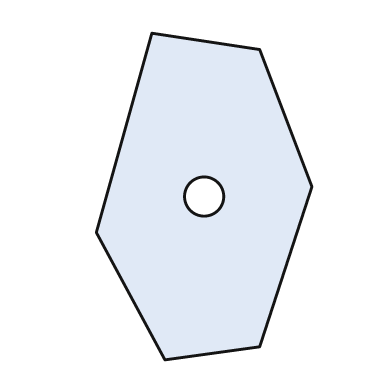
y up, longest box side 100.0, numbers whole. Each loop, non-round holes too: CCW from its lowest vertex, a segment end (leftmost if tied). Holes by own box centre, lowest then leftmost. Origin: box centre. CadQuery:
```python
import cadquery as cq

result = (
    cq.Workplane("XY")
    .moveTo(-12.0, -50.0)
    .lineTo(17.0, -46.0)
    .lineTo(33.0, 3.0)
    .lineTo(17.0, 45.0)
    .lineTo(-16.0, 50.0)
    .lineTo(-33.0, -11.0)
    .close()
    .moveTo(0.0, 0.0)
    .circle(6.0)
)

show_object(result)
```